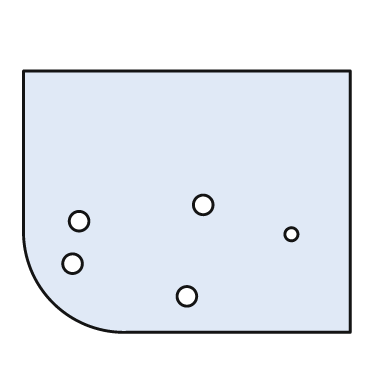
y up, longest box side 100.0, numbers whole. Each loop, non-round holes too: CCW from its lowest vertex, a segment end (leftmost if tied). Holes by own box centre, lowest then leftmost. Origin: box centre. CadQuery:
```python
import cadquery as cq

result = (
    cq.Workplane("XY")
    .moveTo(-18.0, -40.0)
    .lineTo(50.0, -40.0)
    .lineTo(50.0, 40.0)
    .lineTo(-50.0, 40.0)
    .lineTo(-50.0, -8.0)
    .threePointArc((-41.0, -31.0), (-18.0, -40.0))
    .close()
    .moveTo(0.0, -29.0)
    .circle(3.0)
    .moveTo(-35.0, -19.0)
    .circle(3.0)
    .moveTo(32.0, -10.0)
    .circle(2.0)
    .moveTo(-33.0, -6.0)
    .circle(3.0)
    .moveTo(5.0, -1.0)
    .circle(3.0)
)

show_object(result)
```